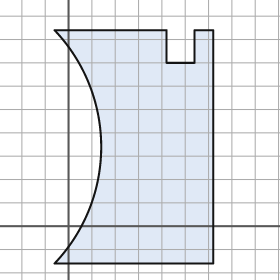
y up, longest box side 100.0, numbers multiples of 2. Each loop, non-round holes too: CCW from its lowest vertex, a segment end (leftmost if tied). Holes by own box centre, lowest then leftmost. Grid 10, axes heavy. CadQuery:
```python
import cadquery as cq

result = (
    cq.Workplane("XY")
    .moveTo(-6.0, -16.0)
    .lineTo(62.0, -16.0)
    .lineTo(62.0, 84.0)
    .lineTo(54.0, 84.0)
    .lineTo(54.0, 70.0)
    .lineTo(42.0, 70.0)
    .lineTo(42.0, 84.0)
    .lineTo(-6.0, 84.0)
    .threePointArc((14.0, 34.0), (-6.0, -16.0))
    .close()
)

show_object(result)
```